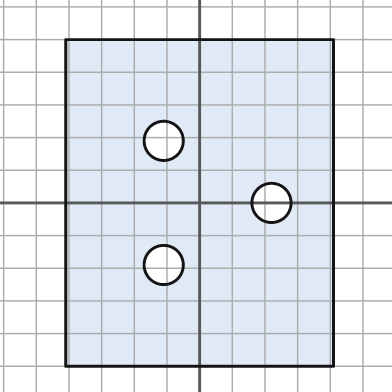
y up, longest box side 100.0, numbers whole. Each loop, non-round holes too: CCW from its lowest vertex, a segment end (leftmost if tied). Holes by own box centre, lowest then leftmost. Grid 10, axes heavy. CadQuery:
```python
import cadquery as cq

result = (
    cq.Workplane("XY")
    .moveTo(-41.0, -50.0)
    .lineTo(41.0, -50.0)
    .lineTo(41.0, 50.0)
    .lineTo(-41.0, 50.0)
    .close()
    .moveTo(-11.0, -19.0)
    .circle(6.0)
    .moveTo(22.0, 0.0)
    .circle(6.0)
    .moveTo(-11.0, 19.0)
    .circle(6.0)
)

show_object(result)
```